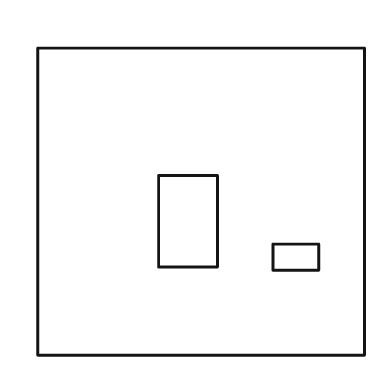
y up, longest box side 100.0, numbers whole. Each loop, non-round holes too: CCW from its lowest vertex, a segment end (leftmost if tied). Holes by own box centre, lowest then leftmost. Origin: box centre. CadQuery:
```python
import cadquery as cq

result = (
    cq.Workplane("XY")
    .moveTo(-50.0, -47.0)
    .lineTo(50.0, -47.0)
    .lineTo(50.0, 47.0)
    .lineTo(-50.0, 47.0)
    .close()
    .moveTo(22.0, -21.0)
    .lineTo(36.0, -21.0)
    .lineTo(36.0, -13.0)
    .lineTo(22.0, -13.0)
    .close()
    .moveTo(-13.0, -20.0)
    .lineTo(5.0, -20.0)
    .lineTo(5.0, 8.0)
    .lineTo(-13.0, 8.0)
    .close()
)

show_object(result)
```